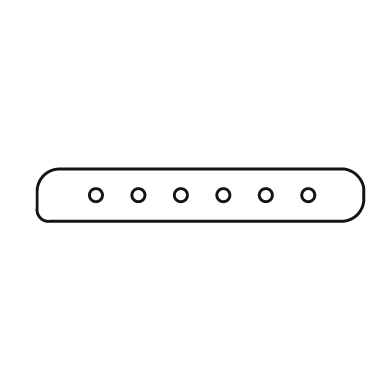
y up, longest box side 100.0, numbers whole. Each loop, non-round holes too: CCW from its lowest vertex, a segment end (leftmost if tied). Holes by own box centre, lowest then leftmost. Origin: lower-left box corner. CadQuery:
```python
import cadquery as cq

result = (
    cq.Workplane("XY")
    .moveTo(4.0, 0.0)
    .lineTo(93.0, 0.0)
    .threePointArc((98.0, 2.0), (100.0, 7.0))
    .lineTo(100.0, 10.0)
    .threePointArc((98.0, 14.0), (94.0, 16.0))
    .lineTo(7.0, 16.0)
    .threePointArc((2.0, 14.0), (0.0, 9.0))
    .lineTo(0.0, 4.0)
    .threePointArc((1.0, 1.0), (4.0, 0.0))
    .close()
    .moveTo(18.0, 8.0)
    .circle(2.0)
    .moveTo(31.0, 8.0)
    .circle(2.0)
    .moveTo(44.0, 8.0)
    .circle(2.0)
    .moveTo(57.0, 8.0)
    .circle(2.0)
    .moveTo(70.0, 8.0)
    .circle(2.0)
    .moveTo(83.0, 8.0)
    .circle(2.0)
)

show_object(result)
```